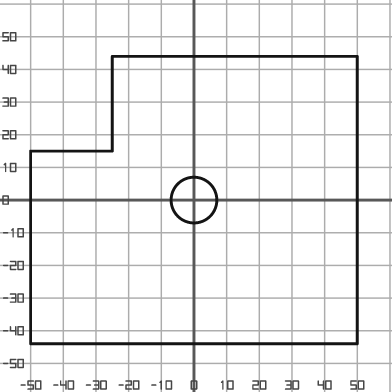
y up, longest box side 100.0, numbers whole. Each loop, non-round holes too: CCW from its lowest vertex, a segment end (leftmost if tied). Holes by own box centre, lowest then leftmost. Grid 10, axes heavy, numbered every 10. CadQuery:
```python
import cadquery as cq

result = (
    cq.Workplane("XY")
    .moveTo(-50.0, -44.0)
    .lineTo(50.0, -44.0)
    .lineTo(50.0, 44.0)
    .lineTo(-25.0, 44.0)
    .lineTo(-25.0, 15.0)
    .lineTo(-50.0, 15.0)
    .close()
    .moveTo(0.0, 0.0)
    .circle(7.0)
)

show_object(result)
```